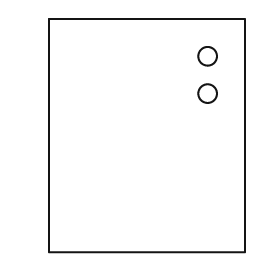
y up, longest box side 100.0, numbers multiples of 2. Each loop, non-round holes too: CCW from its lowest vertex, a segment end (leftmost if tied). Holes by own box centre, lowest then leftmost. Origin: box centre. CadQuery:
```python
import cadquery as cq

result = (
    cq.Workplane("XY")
    .moveTo(-42.0, -50.0)
    .lineTo(42.0, -50.0)
    .lineTo(42.0, 50.0)
    .lineTo(-42.0, 50.0)
    .close()
    .moveTo(26.0, 18.0)
    .circle(4.0)
    .moveTo(26.0, 34.0)
    .circle(4.0)
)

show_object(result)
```